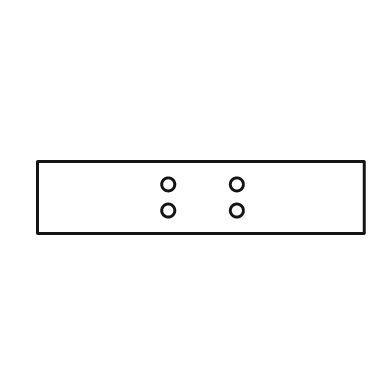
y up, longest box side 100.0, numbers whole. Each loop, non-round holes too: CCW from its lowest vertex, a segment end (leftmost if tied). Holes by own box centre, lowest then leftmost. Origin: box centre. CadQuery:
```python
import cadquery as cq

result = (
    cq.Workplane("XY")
    .moveTo(-50.0, -11.0)
    .lineTo(50.0, -11.0)
    .lineTo(50.0, 11.0)
    .lineTo(-50.0, 11.0)
    .close()
    .moveTo(-10.0, -4.0)
    .circle(2.0)
    .moveTo(11.0, -4.0)
    .circle(2.0)
    .moveTo(-10.0, 4.0)
    .circle(2.0)
    .moveTo(11.0, 4.0)
    .circle(2.0)
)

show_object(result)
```